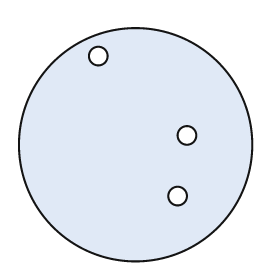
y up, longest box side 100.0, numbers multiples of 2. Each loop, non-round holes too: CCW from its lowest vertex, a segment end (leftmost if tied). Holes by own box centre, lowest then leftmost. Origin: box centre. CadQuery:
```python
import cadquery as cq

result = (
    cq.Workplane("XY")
    .moveTo(0.0, 0.0)
    .circle(50.0)
    .moveTo(18.0, -22.0)
    .circle(4.0)
    .moveTo(22.0, 4.0)
    .circle(4.0)
    .moveTo(-16.0, 38.0)
    .circle(4.0)
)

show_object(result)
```